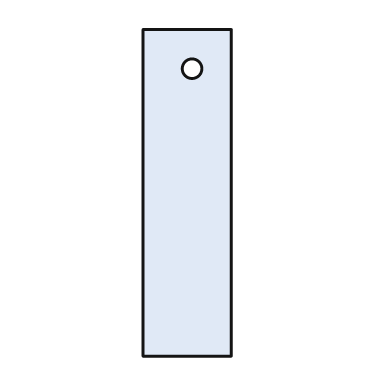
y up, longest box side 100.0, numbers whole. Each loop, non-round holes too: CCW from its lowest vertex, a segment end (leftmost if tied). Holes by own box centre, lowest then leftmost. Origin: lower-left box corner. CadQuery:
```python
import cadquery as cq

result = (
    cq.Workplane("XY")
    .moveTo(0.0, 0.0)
    .lineTo(27.0, 0.0)
    .lineTo(27.0, 100.0)
    .lineTo(0.0, 100.0)
    .close()
    .moveTo(15.0, 88.0)
    .circle(3.0)
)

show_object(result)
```